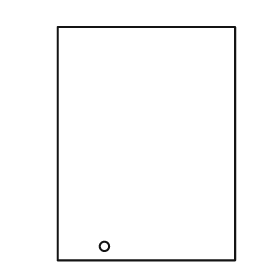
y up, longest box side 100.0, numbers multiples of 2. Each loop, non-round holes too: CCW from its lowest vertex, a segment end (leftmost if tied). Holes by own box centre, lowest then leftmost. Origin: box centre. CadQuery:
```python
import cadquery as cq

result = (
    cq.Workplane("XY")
    .moveTo(-38.0, -50.0)
    .lineTo(38.0, -50.0)
    .lineTo(38.0, 50.0)
    .lineTo(-38.0, 50.0)
    .close()
    .moveTo(-18.0, -44.0)
    .circle(2.0)
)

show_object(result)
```